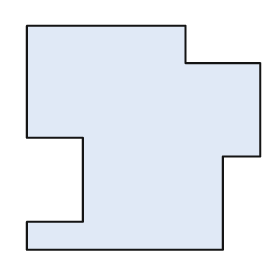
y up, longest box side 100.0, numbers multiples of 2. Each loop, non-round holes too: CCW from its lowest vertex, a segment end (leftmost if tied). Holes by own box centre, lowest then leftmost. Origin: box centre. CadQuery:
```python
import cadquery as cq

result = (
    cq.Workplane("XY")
    .moveTo(-50.0, -48.0)
    .lineTo(34.0, -48.0)
    .lineTo(34.0, -8.0)
    .lineTo(50.0, -8.0)
    .lineTo(50.0, 32.0)
    .lineTo(18.0, 32.0)
    .lineTo(18.0, 48.0)
    .lineTo(-50.0, 48.0)
    .lineTo(-50.0, 0.0)
    .lineTo(-26.0, 0.0)
    .lineTo(-26.0, -36.0)
    .lineTo(-50.0, -36.0)
    .close()
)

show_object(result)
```